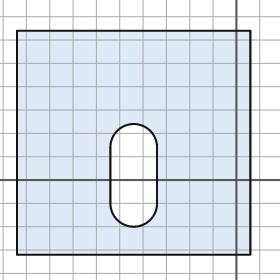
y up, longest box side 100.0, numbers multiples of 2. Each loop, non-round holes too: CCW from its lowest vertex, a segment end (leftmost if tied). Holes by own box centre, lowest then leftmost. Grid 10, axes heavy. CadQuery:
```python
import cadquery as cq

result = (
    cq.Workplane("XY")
    .moveTo(-94.0, -32.0)
    .lineTo(6.0, -32.0)
    .lineTo(6.0, 64.0)
    .lineTo(-94.0, 64.0)
    .close()
    .moveTo(-54.0, -10.0)
    .threePointArc((-44.0, -20.0), (-34.0, -10.0))
    .lineTo(-34.0, 14.0)
    .threePointArc((-44.0, 24.0), (-54.0, 14.0))
    .close()
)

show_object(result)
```